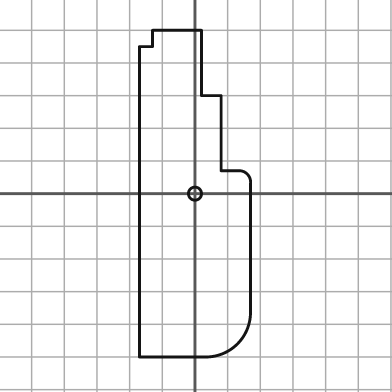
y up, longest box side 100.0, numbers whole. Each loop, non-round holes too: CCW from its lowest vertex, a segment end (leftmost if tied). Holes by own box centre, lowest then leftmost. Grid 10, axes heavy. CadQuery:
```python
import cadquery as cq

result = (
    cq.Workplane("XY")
    .moveTo(-17.0, -50.0)
    .lineTo(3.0, -50.0)
    .threePointArc((13.0, -46.0), (17.0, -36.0))
    .lineTo(17.0, 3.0)
    .threePointArc((16.0, 6.0), (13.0, 7.0))
    .lineTo(8.0, 7.0)
    .lineTo(8.0, 30.0)
    .lineTo(2.0, 30.0)
    .lineTo(2.0, 50.0)
    .lineTo(-13.0, 50.0)
    .lineTo(-13.0, 45.0)
    .lineTo(-17.0, 45.0)
    .close()
    .moveTo(0.0, 0.0)
    .circle(2.0)
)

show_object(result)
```